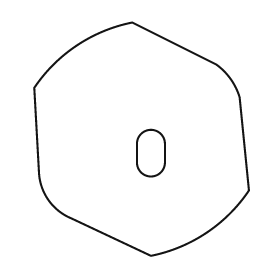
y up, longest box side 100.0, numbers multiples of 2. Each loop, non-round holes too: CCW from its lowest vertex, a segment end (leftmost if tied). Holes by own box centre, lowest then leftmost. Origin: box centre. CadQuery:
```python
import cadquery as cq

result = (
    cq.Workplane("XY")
    .moveTo(4.0, -50.0)
    .threePointArc((28.0, -40.0), (46.0, -22.0))
    .lineTo(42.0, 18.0)
    .threePointArc((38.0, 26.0), (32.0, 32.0))
    .lineTo(-4.0, 50.0)
    .threePointArc((-28.0, 40.0), (-46.0, 22.0))
    .lineTo(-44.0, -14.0)
    .threePointArc((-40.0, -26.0), (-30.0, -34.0))
    .close()
    .moveTo(-2.0, -10.0)
    .threePointArc((4.0, -16.0), (10.0, -10.0))
    .lineTo(10.0, -2.0)
    .threePointArc((4.0, 4.0), (-2.0, -2.0))
    .close()
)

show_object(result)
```